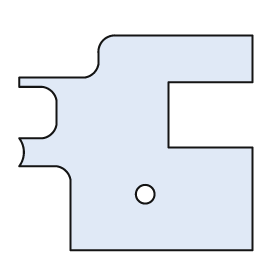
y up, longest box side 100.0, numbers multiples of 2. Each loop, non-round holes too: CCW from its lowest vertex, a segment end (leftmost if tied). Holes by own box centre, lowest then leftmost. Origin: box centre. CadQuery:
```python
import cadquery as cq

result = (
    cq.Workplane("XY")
    .moveTo(-28.0, -46.0)
    .lineTo(50.0, -46.0)
    .lineTo(50.0, -2.0)
    .lineTo(14.0, -2.0)
    .lineTo(14.0, 26.0)
    .lineTo(50.0, 26.0)
    .lineTo(50.0, 46.0)
    .lineTo(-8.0, 46.0)
    .threePointArc((-14.0, 44.0), (-16.0, 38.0))
    .lineTo(-16.0, 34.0)
    .threePointArc((-18.0, 30.0), (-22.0, 28.0))
    .lineTo(-50.0, 28.0)
    .lineTo(-50.0, 24.0)
    .lineTo(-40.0, 24.0)
    .threePointArc((-36.0, 22.0), (-34.0, 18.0))
    .lineTo(-34.0, 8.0)
    .threePointArc((-36.0, 4.0), (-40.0, 2.0))
    .lineTo(-50.0, 2.0)
    .threePointArc((-48.0, -4.0), (-50.0, -10.0))
    .lineTo(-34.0, -10.0)
    .threePointArc((-30.0, -12.0), (-28.0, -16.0))
    .close()
    .moveTo(4.0, -22.0)
    .circle(4.0)
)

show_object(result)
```